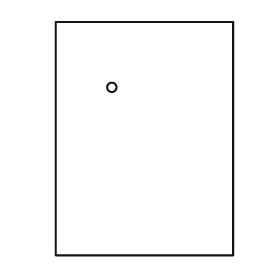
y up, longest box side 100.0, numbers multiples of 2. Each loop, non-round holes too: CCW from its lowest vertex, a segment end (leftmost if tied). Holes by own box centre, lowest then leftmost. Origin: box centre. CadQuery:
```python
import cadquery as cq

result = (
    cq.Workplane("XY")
    .moveTo(-38.0, -50.0)
    .lineTo(38.0, -50.0)
    .lineTo(38.0, 50.0)
    .lineTo(-38.0, 50.0)
    .close()
    .moveTo(-14.0, 22.0)
    .circle(2.0)
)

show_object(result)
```